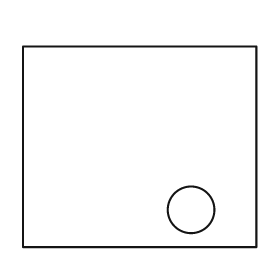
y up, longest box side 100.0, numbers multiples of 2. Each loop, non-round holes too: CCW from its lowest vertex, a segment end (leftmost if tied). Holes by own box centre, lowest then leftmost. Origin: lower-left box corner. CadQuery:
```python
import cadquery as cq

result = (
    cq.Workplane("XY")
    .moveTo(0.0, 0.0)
    .lineTo(100.0, 0.0)
    .lineTo(100.0, 86.0)
    .lineTo(0.0, 86.0)
    .close()
    .moveTo(72.0, 16.0)
    .circle(10.0)
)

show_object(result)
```